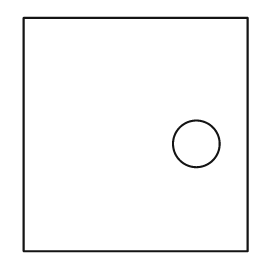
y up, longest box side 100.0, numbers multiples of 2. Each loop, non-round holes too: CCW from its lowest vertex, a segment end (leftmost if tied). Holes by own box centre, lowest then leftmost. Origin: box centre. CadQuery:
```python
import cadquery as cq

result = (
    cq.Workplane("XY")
    .moveTo(-48.0, -50.0)
    .lineTo(48.0, -50.0)
    .lineTo(48.0, 50.0)
    .lineTo(-48.0, 50.0)
    .close()
    .moveTo(26.0, -4.0)
    .circle(10.0)
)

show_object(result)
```